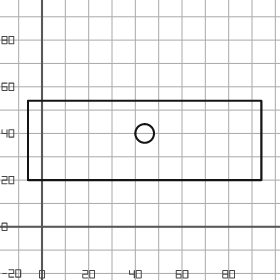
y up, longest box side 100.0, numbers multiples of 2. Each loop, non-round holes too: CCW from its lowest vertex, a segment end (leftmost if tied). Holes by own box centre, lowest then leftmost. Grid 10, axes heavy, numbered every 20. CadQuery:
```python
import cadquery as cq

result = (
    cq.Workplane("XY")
    .moveTo(-6.0, 20.0)
    .lineTo(94.0, 20.0)
    .lineTo(94.0, 54.0)
    .lineTo(-6.0, 54.0)
    .close()
    .moveTo(44.0, 40.0)
    .circle(4.0)
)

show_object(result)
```